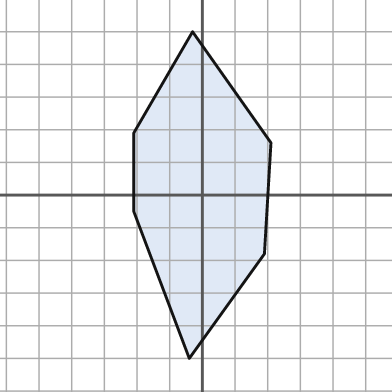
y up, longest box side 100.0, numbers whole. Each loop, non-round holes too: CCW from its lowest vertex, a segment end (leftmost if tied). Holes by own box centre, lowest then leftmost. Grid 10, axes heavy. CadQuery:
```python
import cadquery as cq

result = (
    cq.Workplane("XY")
    .moveTo(-4.0, -50.0)
    .lineTo(19.0, -18.0)
    .lineTo(21.0, 16.0)
    .lineTo(-3.0, 50.0)
    .lineTo(-21.0, 19.0)
    .lineTo(-21.0, -5.0)
    .close()
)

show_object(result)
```